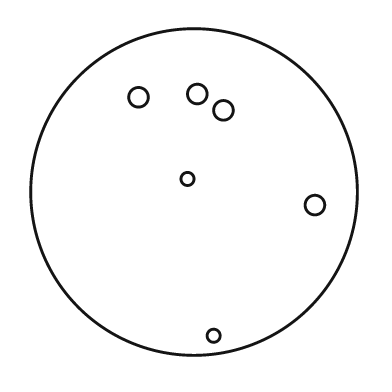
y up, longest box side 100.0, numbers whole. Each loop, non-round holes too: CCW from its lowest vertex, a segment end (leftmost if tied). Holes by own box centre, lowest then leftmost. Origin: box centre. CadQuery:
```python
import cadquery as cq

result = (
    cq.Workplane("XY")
    .moveTo(0.0, 0.0)
    .circle(50.0)
    .moveTo(6.0, -44.0)
    .circle(2.0)
    .moveTo(37.0, -4.0)
    .circle(3.0)
    .moveTo(-2.0, 4.0)
    .circle(2.0)
    .moveTo(9.0, 25.0)
    .circle(3.0)
    .moveTo(-17.0, 29.0)
    .circle(3.0)
    .moveTo(1.0, 30.0)
    .circle(3.0)
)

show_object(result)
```